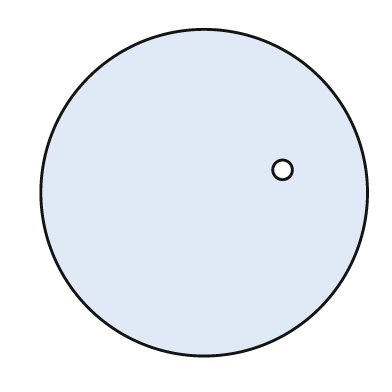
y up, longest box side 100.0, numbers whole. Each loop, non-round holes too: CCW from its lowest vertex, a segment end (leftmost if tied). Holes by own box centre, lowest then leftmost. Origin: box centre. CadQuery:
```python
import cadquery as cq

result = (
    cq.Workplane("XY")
    .moveTo(0.0, 0.0)
    .circle(50.0)
    .moveTo(24.0, 7.0)
    .circle(3.0)
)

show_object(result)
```